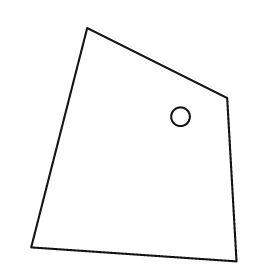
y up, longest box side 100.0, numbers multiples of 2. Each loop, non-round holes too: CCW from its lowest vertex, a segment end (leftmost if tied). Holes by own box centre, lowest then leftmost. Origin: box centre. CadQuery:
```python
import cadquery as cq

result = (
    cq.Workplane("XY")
    .moveTo(44.0, -50.0)
    .lineTo(40.0, 20.0)
    .lineTo(-20.0, 50.0)
    .lineTo(-44.0, -44.0)
    .close()
    .moveTo(20.0, 12.0)
    .circle(4.0)
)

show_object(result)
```